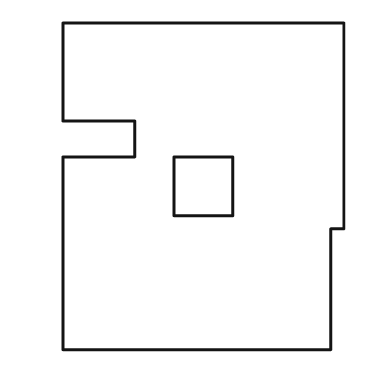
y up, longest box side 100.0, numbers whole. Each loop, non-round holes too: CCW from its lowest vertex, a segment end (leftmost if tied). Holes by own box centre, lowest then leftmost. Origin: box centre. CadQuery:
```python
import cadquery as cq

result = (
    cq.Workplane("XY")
    .moveTo(-43.0, -50.0)
    .lineTo(39.0, -50.0)
    .lineTo(39.0, -13.0)
    .lineTo(43.0, -13.0)
    .lineTo(43.0, 50.0)
    .lineTo(-43.0, 50.0)
    .lineTo(-43.0, 20.0)
    .lineTo(-21.0, 20.0)
    .lineTo(-21.0, 9.0)
    .lineTo(-43.0, 9.0)
    .close()
    .moveTo(-9.0, -9.0)
    .lineTo(9.0, -9.0)
    .lineTo(9.0, 9.0)
    .lineTo(-9.0, 9.0)
    .close()
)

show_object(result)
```